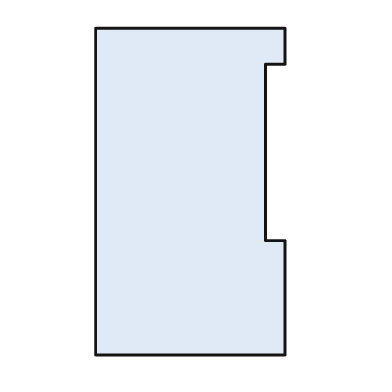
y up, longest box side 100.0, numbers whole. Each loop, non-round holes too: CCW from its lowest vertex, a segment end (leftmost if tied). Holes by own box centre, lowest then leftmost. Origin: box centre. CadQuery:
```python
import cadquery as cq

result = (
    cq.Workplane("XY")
    .moveTo(-29.0, -50.0)
    .lineTo(29.0, -50.0)
    .lineTo(29.0, -15.0)
    .lineTo(23.0, -15.0)
    .lineTo(23.0, 39.0)
    .lineTo(29.0, 39.0)
    .lineTo(29.0, 50.0)
    .lineTo(-29.0, 50.0)
    .close()
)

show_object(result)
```